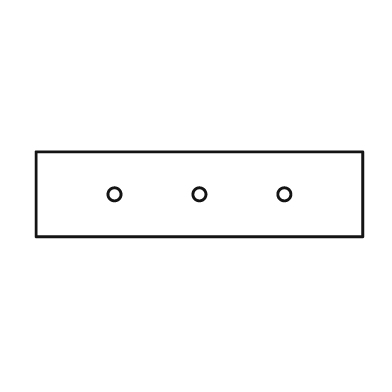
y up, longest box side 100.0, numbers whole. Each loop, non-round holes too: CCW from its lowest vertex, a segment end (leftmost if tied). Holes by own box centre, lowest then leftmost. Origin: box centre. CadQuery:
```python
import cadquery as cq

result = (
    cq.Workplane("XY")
    .moveTo(-50.0, -13.0)
    .lineTo(50.0, -13.0)
    .lineTo(50.0, 13.0)
    .lineTo(-50.0, 13.0)
    .close()
    .moveTo(-26.0, 0.0)
    .circle(2.0)
    .moveTo(0.0, 0.0)
    .circle(2.0)
    .moveTo(26.0, 0.0)
    .circle(2.0)
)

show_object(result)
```